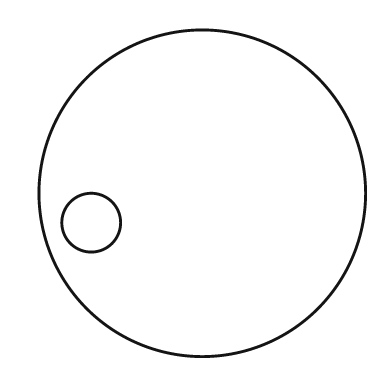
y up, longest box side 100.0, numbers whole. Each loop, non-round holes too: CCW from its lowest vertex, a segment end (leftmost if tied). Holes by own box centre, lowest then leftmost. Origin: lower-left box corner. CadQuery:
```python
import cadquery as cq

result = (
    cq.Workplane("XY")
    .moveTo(50.0, 50.0)
    .circle(50.0)
    .moveTo(16.0, 41.0)
    .circle(9.0)
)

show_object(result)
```